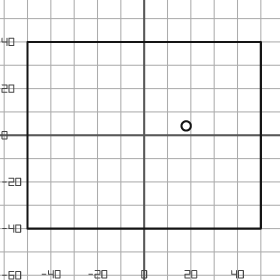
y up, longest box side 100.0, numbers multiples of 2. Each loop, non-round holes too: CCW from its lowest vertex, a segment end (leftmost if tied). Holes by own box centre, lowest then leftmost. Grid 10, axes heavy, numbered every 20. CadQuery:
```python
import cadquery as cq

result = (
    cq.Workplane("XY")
    .moveTo(-50.0, -40.0)
    .lineTo(50.0, -40.0)
    .lineTo(50.0, 40.0)
    .lineTo(-50.0, 40.0)
    .close()
    .moveTo(18.0, 4.0)
    .circle(2.0)
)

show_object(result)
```